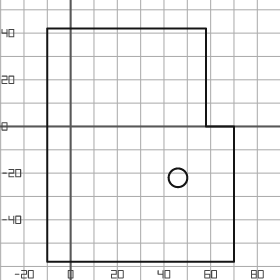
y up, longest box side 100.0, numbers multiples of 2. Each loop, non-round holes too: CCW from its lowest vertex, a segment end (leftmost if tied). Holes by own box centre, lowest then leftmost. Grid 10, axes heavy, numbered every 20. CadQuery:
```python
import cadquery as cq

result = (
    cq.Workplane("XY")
    .moveTo(-10.0, -58.0)
    .lineTo(70.0, -58.0)
    .lineTo(70.0, 0.0)
    .lineTo(58.0, 0.0)
    .lineTo(58.0, 42.0)
    .lineTo(-10.0, 42.0)
    .close()
    .moveTo(46.0, -22.0)
    .circle(4.0)
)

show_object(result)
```